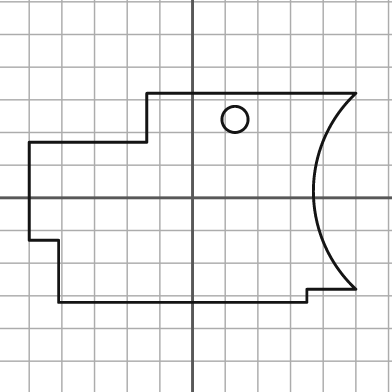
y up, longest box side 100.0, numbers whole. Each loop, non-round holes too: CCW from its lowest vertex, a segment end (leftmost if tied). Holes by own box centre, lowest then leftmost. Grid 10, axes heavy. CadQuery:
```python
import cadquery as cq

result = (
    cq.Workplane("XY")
    .moveTo(-41.0, -32.0)
    .lineTo(35.0, -32.0)
    .lineTo(35.0, -28.0)
    .lineTo(50.0, -28.0)
    .threePointArc((37.0, 2.0), (50.0, 32.0))
    .lineTo(-14.0, 32.0)
    .lineTo(-14.0, 17.0)
    .lineTo(-50.0, 17.0)
    .lineTo(-50.0, -13.0)
    .lineTo(-41.0, -13.0)
    .close()
    .moveTo(13.0, 24.0)
    .circle(4.0)
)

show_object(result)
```